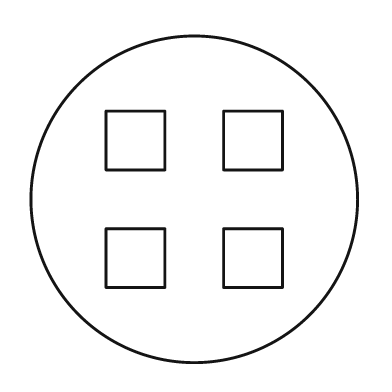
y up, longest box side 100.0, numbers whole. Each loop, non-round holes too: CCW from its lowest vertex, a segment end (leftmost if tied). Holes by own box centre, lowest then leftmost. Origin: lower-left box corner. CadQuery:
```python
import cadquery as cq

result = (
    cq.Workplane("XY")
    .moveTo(50.0, 50.0)
    .circle(50.0)
    .moveTo(23.0, 23.0)
    .lineTo(41.0, 23.0)
    .lineTo(41.0, 41.0)
    .lineTo(23.0, 41.0)
    .close()
    .moveTo(59.0, 23.0)
    .lineTo(77.0, 23.0)
    .lineTo(77.0, 41.0)
    .lineTo(59.0, 41.0)
    .close()
    .moveTo(23.0, 59.0)
    .lineTo(41.0, 59.0)
    .lineTo(41.0, 77.0)
    .lineTo(23.0, 77.0)
    .close()
    .moveTo(59.0, 59.0)
    .lineTo(77.0, 59.0)
    .lineTo(77.0, 77.0)
    .lineTo(59.0, 77.0)
    .close()
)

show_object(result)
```